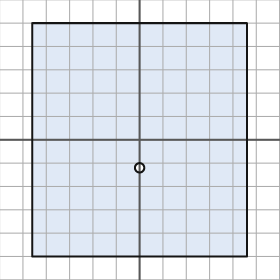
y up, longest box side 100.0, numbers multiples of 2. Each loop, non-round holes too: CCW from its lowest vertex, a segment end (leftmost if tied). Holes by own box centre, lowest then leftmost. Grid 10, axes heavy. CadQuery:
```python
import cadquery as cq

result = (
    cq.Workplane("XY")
    .moveTo(-46.0, -50.0)
    .lineTo(46.0, -50.0)
    .lineTo(46.0, 50.0)
    .lineTo(-46.0, 50.0)
    .close()
    .moveTo(0.0, -12.0)
    .circle(2.0)
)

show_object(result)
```